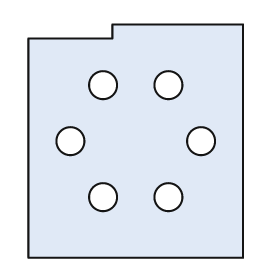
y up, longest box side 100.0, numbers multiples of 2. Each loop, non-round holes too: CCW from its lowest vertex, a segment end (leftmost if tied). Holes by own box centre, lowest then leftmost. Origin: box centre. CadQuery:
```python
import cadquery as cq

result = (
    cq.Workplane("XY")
    .moveTo(-46.0, -50.0)
    .lineTo(46.0, -50.0)
    .lineTo(46.0, 50.0)
    .lineTo(-10.0, 50.0)
    .lineTo(-10.0, 44.0)
    .lineTo(-46.0, 44.0)
    .close()
    .moveTo(-14.0, -24.0)
    .circle(6.0)
    .moveTo(14.0, -24.0)
    .circle(6.0)
    .moveTo(-28.0, 0.0)
    .circle(6.0)
    .moveTo(28.0, 0.0)
    .circle(6.0)
    .moveTo(-14.0, 24.0)
    .circle(6.0)
    .moveTo(14.0, 24.0)
    .circle(6.0)
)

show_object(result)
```